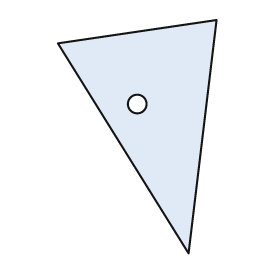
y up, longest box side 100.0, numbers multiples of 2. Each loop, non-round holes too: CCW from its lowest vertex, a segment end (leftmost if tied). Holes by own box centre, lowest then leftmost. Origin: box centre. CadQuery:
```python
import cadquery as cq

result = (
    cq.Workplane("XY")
    .moveTo(22.0, -50.0)
    .lineTo(34.0, 50.0)
    .lineTo(-34.0, 40.0)
    .close()
    .moveTo(0.0, 14.0)
    .circle(4.0)
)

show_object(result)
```